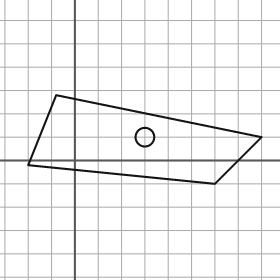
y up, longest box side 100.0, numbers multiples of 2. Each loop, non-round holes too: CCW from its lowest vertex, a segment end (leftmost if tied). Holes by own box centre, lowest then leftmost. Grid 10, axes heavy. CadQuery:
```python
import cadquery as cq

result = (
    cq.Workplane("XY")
    .moveTo(60.0, -10.0)
    .lineTo(80.0, 10.0)
    .lineTo(-8.0, 28.0)
    .lineTo(-20.0, -2.0)
    .close()
    .moveTo(30.0, 10.0)
    .circle(4.0)
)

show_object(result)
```